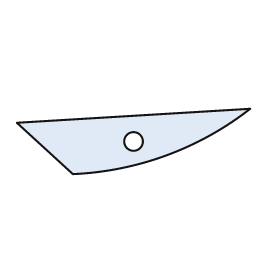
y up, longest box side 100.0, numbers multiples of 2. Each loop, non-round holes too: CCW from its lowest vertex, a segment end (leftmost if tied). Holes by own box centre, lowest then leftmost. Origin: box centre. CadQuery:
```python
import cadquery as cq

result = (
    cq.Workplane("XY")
    .moveTo(-26.0, -14.0)
    .threePointArc((14.0, -6.0), (50.0, 14.0))
    .lineTo(-50.0, 8.0)
    .close()
    .moveTo(0.0, 0.0)
    .circle(4.0)
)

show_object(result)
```